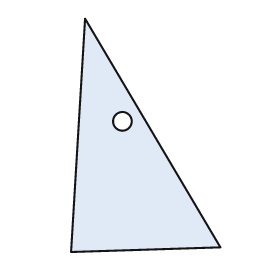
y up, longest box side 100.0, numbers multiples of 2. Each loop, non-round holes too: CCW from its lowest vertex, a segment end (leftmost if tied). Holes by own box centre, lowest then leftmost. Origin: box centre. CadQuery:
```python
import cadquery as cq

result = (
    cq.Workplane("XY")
    .moveTo(-32.0, -50.0)
    .lineTo(32.0, -48.0)
    .lineTo(-26.0, 50.0)
    .close()
    .moveTo(-10.0, 6.0)
    .circle(4.0)
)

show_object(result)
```